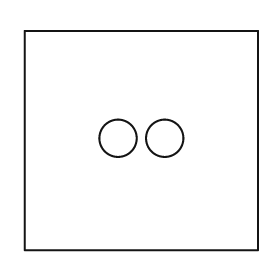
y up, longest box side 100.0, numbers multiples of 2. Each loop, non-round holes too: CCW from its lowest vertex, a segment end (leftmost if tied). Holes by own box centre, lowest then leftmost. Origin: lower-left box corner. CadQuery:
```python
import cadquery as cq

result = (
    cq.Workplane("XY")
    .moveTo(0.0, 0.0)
    .lineTo(100.0, 0.0)
    .lineTo(100.0, 94.0)
    .lineTo(0.0, 94.0)
    .close()
    .moveTo(40.0, 48.0)
    .circle(8.0)
    .moveTo(60.0, 48.0)
    .circle(8.0)
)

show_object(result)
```